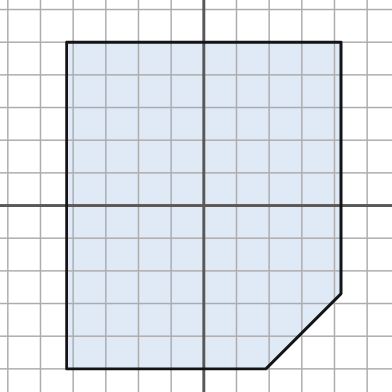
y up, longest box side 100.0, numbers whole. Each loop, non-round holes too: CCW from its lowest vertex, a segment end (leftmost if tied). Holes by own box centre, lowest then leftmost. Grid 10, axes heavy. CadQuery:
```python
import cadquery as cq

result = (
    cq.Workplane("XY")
    .moveTo(-42.0, -50.0)
    .lineTo(19.0, -50.0)
    .lineTo(42.0, -27.0)
    .lineTo(42.0, 50.0)
    .lineTo(-42.0, 50.0)
    .close()
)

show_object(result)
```